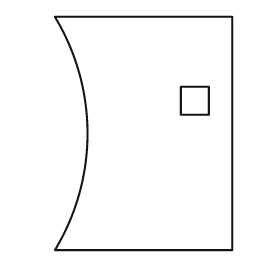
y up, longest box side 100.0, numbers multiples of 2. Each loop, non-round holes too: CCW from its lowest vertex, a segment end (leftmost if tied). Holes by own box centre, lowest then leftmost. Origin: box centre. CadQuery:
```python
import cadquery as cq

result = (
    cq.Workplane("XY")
    .moveTo(-38.0, -50.0)
    .lineTo(38.0, -50.0)
    .lineTo(38.0, 50.0)
    .lineTo(-38.0, 50.0)
    .threePointArc((-24.0, 0.0), (-38.0, -50.0))
    .close()
    .moveTo(16.0, 8.0)
    .lineTo(28.0, 8.0)
    .lineTo(28.0, 20.0)
    .lineTo(16.0, 20.0)
    .close()
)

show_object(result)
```